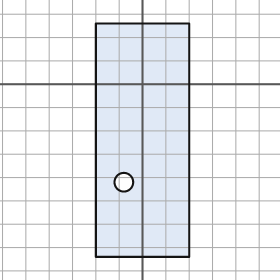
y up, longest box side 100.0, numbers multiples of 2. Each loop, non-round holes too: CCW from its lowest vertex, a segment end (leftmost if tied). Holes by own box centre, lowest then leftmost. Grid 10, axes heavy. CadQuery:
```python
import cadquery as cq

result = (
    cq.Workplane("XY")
    .moveTo(-20.0, -74.0)
    .lineTo(20.0, -74.0)
    .lineTo(20.0, 26.0)
    .lineTo(-20.0, 26.0)
    .close()
    .moveTo(-8.0, -42.0)
    .circle(4.0)
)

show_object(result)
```